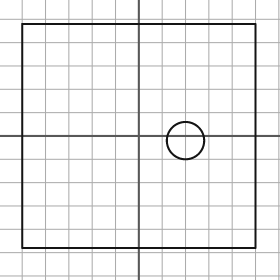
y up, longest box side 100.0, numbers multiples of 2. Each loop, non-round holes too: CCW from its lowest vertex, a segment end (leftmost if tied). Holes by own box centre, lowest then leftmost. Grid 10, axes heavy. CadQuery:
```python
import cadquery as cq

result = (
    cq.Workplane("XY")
    .moveTo(-50.0, -48.0)
    .lineTo(50.0, -48.0)
    .lineTo(50.0, 48.0)
    .lineTo(-50.0, 48.0)
    .close()
    .moveTo(20.0, -2.0)
    .circle(8.0)
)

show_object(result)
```